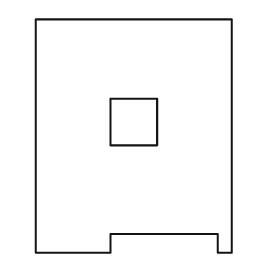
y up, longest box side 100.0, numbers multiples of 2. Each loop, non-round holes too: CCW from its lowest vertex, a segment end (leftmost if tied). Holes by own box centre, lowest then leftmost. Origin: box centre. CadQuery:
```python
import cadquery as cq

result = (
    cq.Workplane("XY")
    .moveTo(-42.0, -50.0)
    .lineTo(-10.0, -50.0)
    .lineTo(-10.0, -42.0)
    .lineTo(36.0, -42.0)
    .lineTo(36.0, -50.0)
    .lineTo(42.0, -50.0)
    .lineTo(42.0, 50.0)
    .lineTo(-42.0, 50.0)
    .close()
    .moveTo(-10.0, -4.0)
    .lineTo(10.0, -4.0)
    .lineTo(10.0, 16.0)
    .lineTo(-10.0, 16.0)
    .close()
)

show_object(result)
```